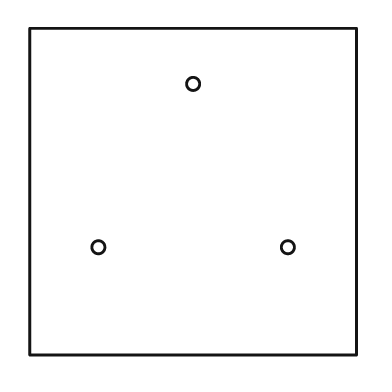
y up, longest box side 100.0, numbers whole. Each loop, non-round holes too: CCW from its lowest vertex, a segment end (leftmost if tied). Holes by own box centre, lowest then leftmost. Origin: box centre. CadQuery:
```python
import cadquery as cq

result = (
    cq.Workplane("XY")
    .moveTo(-50.0, -50.0)
    .lineTo(50.0, -50.0)
    .lineTo(50.0, 50.0)
    .lineTo(-50.0, 50.0)
    .close()
    .moveTo(-29.0, -17.0)
    .circle(2.0)
    .moveTo(29.0, -17.0)
    .circle(2.0)
    .moveTo(0.0, 33.0)
    .circle(2.0)
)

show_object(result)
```